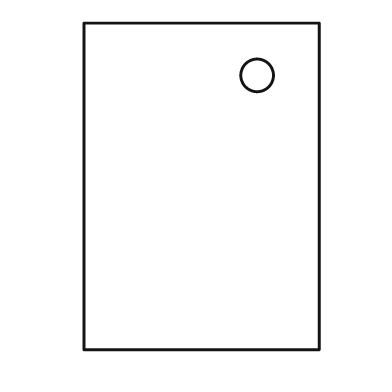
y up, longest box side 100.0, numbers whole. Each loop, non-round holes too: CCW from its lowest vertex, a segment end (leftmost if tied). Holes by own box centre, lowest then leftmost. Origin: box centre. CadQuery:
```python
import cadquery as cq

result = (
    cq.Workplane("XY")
    .moveTo(-36.0, -50.0)
    .lineTo(36.0, -50.0)
    .lineTo(36.0, 50.0)
    .lineTo(-36.0, 50.0)
    .close()
    .moveTo(17.0, 34.0)
    .circle(5.0)
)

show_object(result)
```